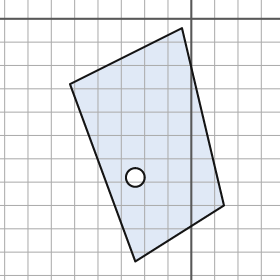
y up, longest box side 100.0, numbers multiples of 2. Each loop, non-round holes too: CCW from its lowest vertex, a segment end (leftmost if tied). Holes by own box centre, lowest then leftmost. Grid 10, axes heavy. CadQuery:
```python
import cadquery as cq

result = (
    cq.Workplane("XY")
    .moveTo(-24.0, -104.0)
    .lineTo(14.0, -80.0)
    .lineTo(-4.0, -4.0)
    .lineTo(-52.0, -28.0)
    .close()
    .moveTo(-24.0, -68.0)
    .circle(4.0)
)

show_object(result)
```